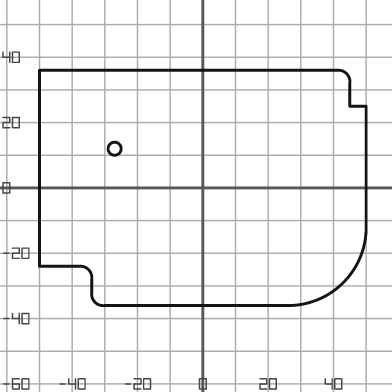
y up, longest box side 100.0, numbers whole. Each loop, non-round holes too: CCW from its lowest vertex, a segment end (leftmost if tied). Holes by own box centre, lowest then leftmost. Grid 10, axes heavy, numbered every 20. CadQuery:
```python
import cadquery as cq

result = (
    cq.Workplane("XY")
    .moveTo(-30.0, -36.0)
    .lineTo(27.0, -36.0)
    .threePointArc((43.0, -29.0), (50.0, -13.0))
    .lineTo(50.0, 25.0)
    .lineTo(45.0, 25.0)
    .lineTo(45.0, 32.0)
    .threePointArc((44.0, 35.0), (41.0, 36.0))
    .lineTo(-50.0, 36.0)
    .lineTo(-50.0, -24.0)
    .lineTo(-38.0, -24.0)
    .threePointArc((-35.0, -25.0), (-34.0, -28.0))
    .lineTo(-34.0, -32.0)
    .threePointArc((-33.0, -35.0), (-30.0, -36.0))
    .close()
    .moveTo(-27.0, 12.0)
    .circle(2.0)
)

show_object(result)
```